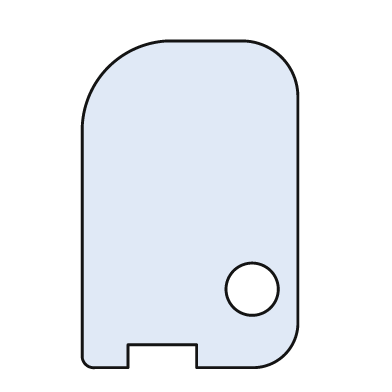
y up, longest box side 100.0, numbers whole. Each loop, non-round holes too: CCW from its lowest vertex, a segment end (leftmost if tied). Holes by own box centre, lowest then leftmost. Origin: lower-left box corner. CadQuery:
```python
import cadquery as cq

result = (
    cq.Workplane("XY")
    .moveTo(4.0, 0.0)
    .lineTo(14.0, 0.0)
    .lineTo(14.0, 7.0)
    .lineTo(35.0, 7.0)
    .lineTo(35.0, 0.0)
    .lineTo(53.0, 0.0)
    .threePointArc((62.0, 4.0), (66.0, 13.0))
    .lineTo(66.0, 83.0)
    .threePointArc((61.0, 95.0), (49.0, 100.0))
    .lineTo(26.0, 100.0)
    .threePointArc((8.0, 92.0), (0.0, 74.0))
    .lineTo(0.0, 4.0)
    .threePointArc((1.0, 1.0), (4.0, 0.0))
    .close()
    .moveTo(52.0, 24.0)
    .circle(8.0)
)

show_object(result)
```